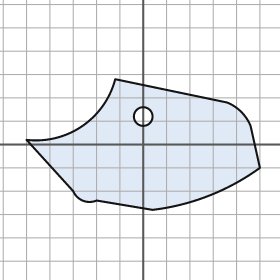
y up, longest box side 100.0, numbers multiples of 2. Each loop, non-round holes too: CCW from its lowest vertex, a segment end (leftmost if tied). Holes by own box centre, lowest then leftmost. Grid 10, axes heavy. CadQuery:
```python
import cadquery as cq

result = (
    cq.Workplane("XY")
    .moveTo(4.0, -28.0)
    .threePointArc((28.0, -22.0), (50.0, -10.0))
    .lineTo(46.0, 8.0)
    .threePointArc((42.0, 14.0), (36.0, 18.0))
    .lineTo(-12.0, 28.0)
    .threePointArc((-26.0, 8.0), (-50.0, 2.0))
    .lineTo(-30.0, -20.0)
    .threePointArc((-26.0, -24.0), (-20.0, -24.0))
    .close()
    .moveTo(0.0, 12.0)
    .circle(4.0)
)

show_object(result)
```